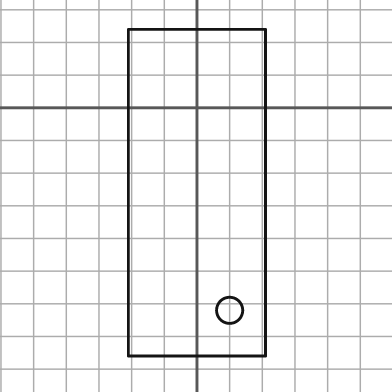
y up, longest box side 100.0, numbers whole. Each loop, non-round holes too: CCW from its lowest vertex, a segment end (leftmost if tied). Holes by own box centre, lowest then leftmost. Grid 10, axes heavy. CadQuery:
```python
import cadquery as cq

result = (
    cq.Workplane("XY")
    .moveTo(-21.0, -76.0)
    .lineTo(21.0, -76.0)
    .lineTo(21.0, 24.0)
    .lineTo(-21.0, 24.0)
    .close()
    .moveTo(10.0, -62.0)
    .circle(4.0)
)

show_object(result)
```